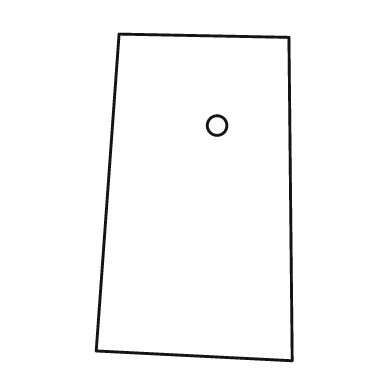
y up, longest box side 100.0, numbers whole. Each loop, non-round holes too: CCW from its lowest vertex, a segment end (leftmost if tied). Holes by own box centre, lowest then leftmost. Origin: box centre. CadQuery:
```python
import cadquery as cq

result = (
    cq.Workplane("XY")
    .moveTo(30.0, -50.0)
    .lineTo(29.0, 49.0)
    .lineTo(-23.0, 50.0)
    .lineTo(-30.0, -47.0)
    .close()
    .moveTo(7.0, 22.0)
    .circle(3.0)
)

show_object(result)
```